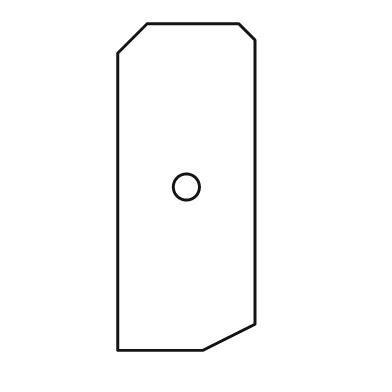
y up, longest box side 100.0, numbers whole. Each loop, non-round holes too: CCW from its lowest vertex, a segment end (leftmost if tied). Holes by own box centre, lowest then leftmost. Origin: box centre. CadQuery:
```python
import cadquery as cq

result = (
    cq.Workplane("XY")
    .moveTo(-21.0, -50.0)
    .lineTo(5.0, -50.0)
    .lineTo(21.0, -42.0)
    .lineTo(21.0, 45.0)
    .lineTo(16.0, 50.0)
    .lineTo(-12.0, 50.0)
    .lineTo(-21.0, 41.0)
    .close()
    .moveTo(0.0, 0.0)
    .circle(4.0)
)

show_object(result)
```